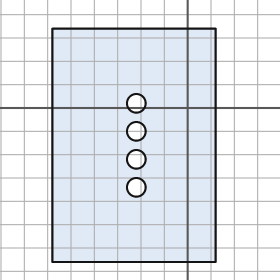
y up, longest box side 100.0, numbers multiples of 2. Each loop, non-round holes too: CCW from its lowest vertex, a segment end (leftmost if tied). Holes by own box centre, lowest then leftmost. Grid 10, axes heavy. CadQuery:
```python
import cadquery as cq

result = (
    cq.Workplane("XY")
    .moveTo(-58.0, -66.0)
    .lineTo(12.0, -66.0)
    .lineTo(12.0, 34.0)
    .lineTo(-58.0, 34.0)
    .close()
    .moveTo(-22.0, -34.0)
    .circle(4.0)
    .moveTo(-22.0, -22.0)
    .circle(4.0)
    .moveTo(-22.0, -10.0)
    .circle(4.0)
    .moveTo(-22.0, 2.0)
    .circle(4.0)
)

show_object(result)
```